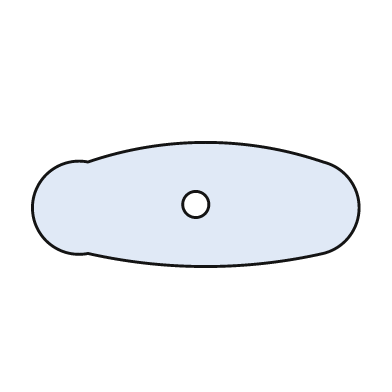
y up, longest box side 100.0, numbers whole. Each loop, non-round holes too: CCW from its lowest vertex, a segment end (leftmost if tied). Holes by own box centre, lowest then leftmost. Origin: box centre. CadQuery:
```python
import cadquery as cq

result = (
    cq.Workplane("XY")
    .moveTo(-33.0, -15.0)
    .threePointArc((3.0, -19.0), (39.0, -15.0))
    .threePointArc((50.0, -1.0), (39.0, 13.0))
    .threePointArc((3.0, 19.0), (-33.0, 13.0))
    .threePointArc((-50.0, -1.0), (-33.0, -15.0))
    .close()
    .moveTo(0.0, 0.0)
    .circle(4.0)
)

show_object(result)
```